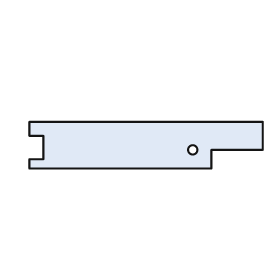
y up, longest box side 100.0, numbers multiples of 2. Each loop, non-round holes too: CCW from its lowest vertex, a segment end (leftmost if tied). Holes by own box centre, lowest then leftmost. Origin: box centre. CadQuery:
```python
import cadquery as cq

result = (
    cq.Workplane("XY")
    .moveTo(-50.0, -10.0)
    .lineTo(28.0, -10.0)
    .lineTo(28.0, -2.0)
    .lineTo(50.0, -2.0)
    .lineTo(50.0, 10.0)
    .lineTo(-50.0, 10.0)
    .lineTo(-50.0, 4.0)
    .lineTo(-44.0, 4.0)
    .lineTo(-44.0, -6.0)
    .lineTo(-50.0, -6.0)
    .close()
    .moveTo(20.0, -2.0)
    .circle(2.0)
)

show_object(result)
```